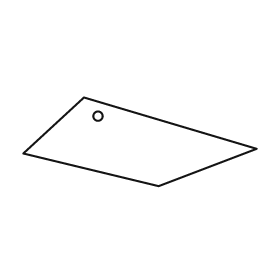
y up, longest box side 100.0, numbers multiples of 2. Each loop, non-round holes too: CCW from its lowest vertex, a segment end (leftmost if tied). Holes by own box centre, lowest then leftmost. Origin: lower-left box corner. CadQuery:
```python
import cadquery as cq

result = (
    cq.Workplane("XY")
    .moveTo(58.0, 0.0)
    .lineTo(100.0, 16.0)
    .lineTo(26.0, 38.0)
    .lineTo(0.0, 14.0)
    .close()
    .moveTo(32.0, 30.0)
    .circle(2.0)
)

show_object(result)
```